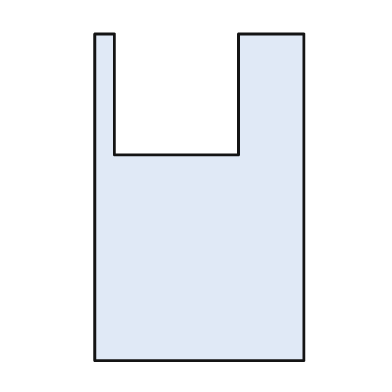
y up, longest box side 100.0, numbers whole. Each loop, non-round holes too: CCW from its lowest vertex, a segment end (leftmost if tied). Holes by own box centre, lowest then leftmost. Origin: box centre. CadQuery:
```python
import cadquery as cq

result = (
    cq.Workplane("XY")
    .moveTo(-32.0, -50.0)
    .lineTo(32.0, -50.0)
    .lineTo(32.0, 50.0)
    .lineTo(12.0, 50.0)
    .lineTo(12.0, 13.0)
    .lineTo(-26.0, 13.0)
    .lineTo(-26.0, 50.0)
    .lineTo(-32.0, 50.0)
    .close()
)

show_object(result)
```